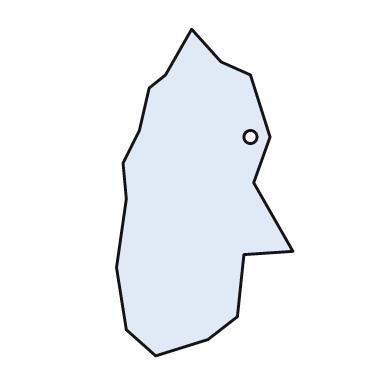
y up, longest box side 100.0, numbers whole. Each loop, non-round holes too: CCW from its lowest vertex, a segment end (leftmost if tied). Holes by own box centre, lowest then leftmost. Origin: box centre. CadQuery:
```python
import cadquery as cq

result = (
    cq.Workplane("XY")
    .moveTo(-15.0, -50.0)
    .lineTo(1.0, -45.0)
    .lineTo(10.0, -38.0)
    .lineTo(12.0, -19.0)
    .lineTo(27.0, -18.0)
    .lineTo(15.0, 3.0)
    .lineTo(20.0, 17.0)
    .lineTo(14.0, 36.0)
    .lineTo(5.0, 40.0)
    .lineTo(-4.0, 50.0)
    .lineTo(-12.0, 36.0)
    .lineTo(-17.0, 32.0)
    .lineTo(-20.0, 19.0)
    .lineTo(-25.0, 9.0)
    .lineTo(-24.0, -2.0)
    .lineTo(-27.0, -23.0)
    .lineTo(-24.0, -42.0)
    .close()
    .moveTo(14.0, 17.0)
    .circle(2.0)
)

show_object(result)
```